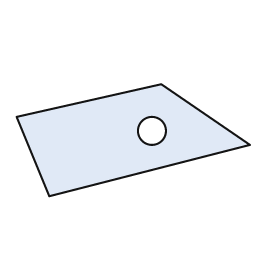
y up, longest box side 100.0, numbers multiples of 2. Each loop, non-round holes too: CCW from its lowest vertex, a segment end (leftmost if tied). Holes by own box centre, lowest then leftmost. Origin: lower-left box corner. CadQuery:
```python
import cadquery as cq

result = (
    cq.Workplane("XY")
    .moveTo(14.0, 0.0)
    .lineTo(100.0, 22.0)
    .lineTo(62.0, 48.0)
    .lineTo(0.0, 34.0)
    .close()
    .moveTo(58.0, 28.0)
    .circle(6.0)
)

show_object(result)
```